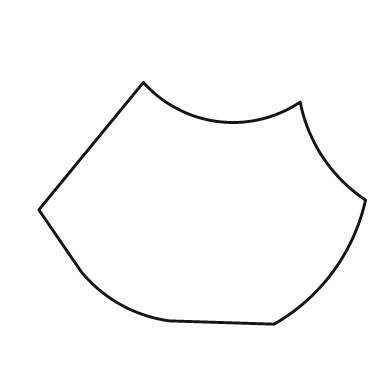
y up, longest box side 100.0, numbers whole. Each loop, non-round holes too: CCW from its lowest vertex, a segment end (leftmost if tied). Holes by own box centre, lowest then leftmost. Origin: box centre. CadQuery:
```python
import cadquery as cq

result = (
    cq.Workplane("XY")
    .moveTo(22.0, -37.0)
    .threePointArc((40.0, -21.0), (50.0, 1.0))
    .threePointArc((37.0, 14.0), (30.0, 31.0))
    .threePointArc((5.0, 25.0), (-18.0, 37.0))
    .lineTo(-50.0, -2.0)
    .lineTo(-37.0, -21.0)
    .threePointArc((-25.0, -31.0), (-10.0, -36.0))
    .close()
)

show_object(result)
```